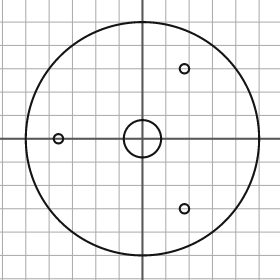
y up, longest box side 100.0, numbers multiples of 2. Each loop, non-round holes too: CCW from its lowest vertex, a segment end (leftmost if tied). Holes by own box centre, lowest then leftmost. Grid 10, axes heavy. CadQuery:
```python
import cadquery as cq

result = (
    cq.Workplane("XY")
    .moveTo(0.0, 0.0)
    .circle(50.0)
    .moveTo(18.0, -30.0)
    .circle(2.0)
    .moveTo(-36.0, 0.0)
    .circle(2.0)
    .moveTo(0.0, 0.0)
    .circle(8.0)
    .moveTo(18.0, 30.0)
    .circle(2.0)
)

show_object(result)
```